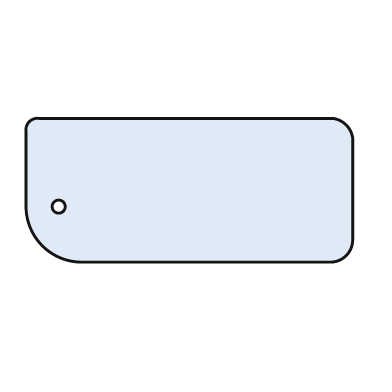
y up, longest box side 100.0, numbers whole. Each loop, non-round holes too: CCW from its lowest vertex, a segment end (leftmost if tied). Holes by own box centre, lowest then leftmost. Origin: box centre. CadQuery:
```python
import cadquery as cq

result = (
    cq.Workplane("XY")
    .moveTo(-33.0, -22.0)
    .lineTo(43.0, -22.0)
    .threePointArc((48.0, -20.0), (50.0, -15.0))
    .lineTo(50.0, 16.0)
    .threePointArc((48.0, 20.0), (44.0, 22.0))
    .lineTo(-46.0, 22.0)
    .threePointArc((-49.0, 21.0), (-50.0, 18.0))
    .lineTo(-50.0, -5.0)
    .threePointArc((-45.0, -17.0), (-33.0, -22.0))
    .close()
    .moveTo(-40.0, -5.0)
    .circle(2.0)
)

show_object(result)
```